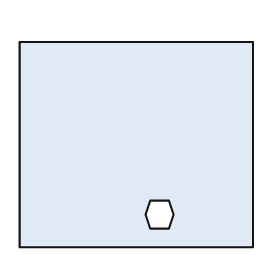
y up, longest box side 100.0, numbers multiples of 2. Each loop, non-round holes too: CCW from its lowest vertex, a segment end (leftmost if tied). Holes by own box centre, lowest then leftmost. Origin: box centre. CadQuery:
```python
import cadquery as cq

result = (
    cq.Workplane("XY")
    .moveTo(-50.0, -44.0)
    .lineTo(50.0, -44.0)
    .lineTo(50.0, 44.0)
    .lineTo(-50.0, 44.0)
    .close()
    .moveTo(6.0, -36.0)
    .lineTo(14.0, -36.0)
    .lineTo(16.0, -30.0)
    .lineTo(14.0, -24.0)
    .lineTo(6.0, -24.0)
    .lineTo(4.0, -30.0)
    .close()
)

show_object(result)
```